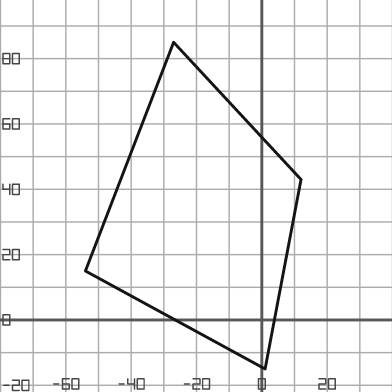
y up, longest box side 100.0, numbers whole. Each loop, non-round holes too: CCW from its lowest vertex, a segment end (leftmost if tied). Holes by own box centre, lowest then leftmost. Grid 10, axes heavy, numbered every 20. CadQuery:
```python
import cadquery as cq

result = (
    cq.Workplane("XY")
    .moveTo(1.0, -15.0)
    .lineTo(12.0, 43.0)
    .lineTo(-27.0, 85.0)
    .lineTo(-54.0, 15.0)
    .close()
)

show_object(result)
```